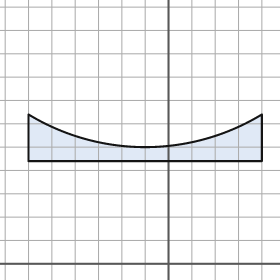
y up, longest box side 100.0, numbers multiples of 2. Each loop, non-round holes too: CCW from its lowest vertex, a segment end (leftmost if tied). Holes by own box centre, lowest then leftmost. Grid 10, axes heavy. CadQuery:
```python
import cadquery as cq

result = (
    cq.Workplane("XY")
    .moveTo(-60.0, 44.0)
    .lineTo(40.0, 44.0)
    .lineTo(40.0, 64.0)
    .threePointArc((-10.0, 50.0), (-60.0, 64.0))
    .close()
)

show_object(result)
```